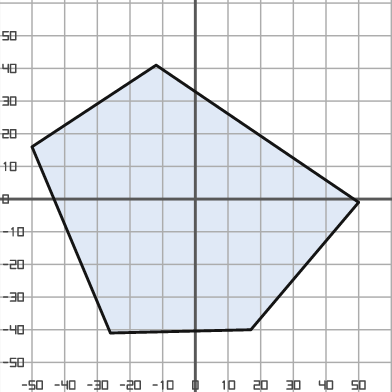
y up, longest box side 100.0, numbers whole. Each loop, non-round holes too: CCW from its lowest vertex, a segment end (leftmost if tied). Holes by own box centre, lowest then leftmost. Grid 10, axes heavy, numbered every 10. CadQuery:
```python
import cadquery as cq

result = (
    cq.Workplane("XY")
    .moveTo(-26.0, -41.0)
    .lineTo(17.0, -40.0)
    .lineTo(50.0, -1.0)
    .lineTo(-12.0, 41.0)
    .lineTo(-50.0, 16.0)
    .close()
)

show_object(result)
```